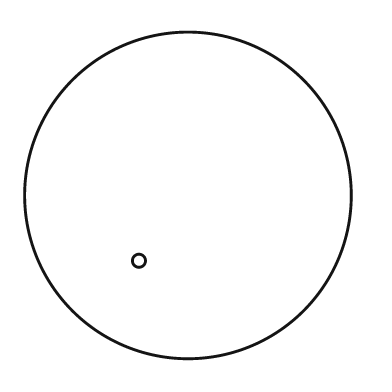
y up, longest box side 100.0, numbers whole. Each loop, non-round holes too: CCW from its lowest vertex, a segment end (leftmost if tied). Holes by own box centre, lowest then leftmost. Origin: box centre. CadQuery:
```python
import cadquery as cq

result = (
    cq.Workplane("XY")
    .moveTo(0.0, 0.0)
    .circle(50.0)
    .moveTo(-15.0, -20.0)
    .circle(2.0)
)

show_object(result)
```